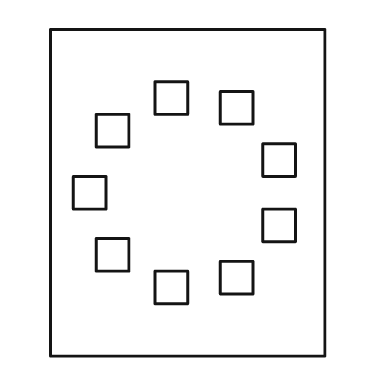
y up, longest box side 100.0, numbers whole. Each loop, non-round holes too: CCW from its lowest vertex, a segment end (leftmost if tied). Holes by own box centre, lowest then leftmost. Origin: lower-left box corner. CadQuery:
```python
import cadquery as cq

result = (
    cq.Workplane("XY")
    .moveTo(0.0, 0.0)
    .lineTo(84.0, 0.0)
    .lineTo(84.0, 100.0)
    .lineTo(0.0, 100.0)
    .close()
    .moveTo(32.0, 16.0)
    .lineTo(42.0, 16.0)
    .lineTo(42.0, 26.0)
    .lineTo(32.0, 26.0)
    .close()
    .moveTo(52.0, 19.0)
    .lineTo(62.0, 19.0)
    .lineTo(62.0, 29.0)
    .lineTo(52.0, 29.0)
    .close()
    .moveTo(14.0, 26.0)
    .lineTo(24.0, 26.0)
    .lineTo(24.0, 36.0)
    .lineTo(14.0, 36.0)
    .close()
    .moveTo(65.0, 35.0)
    .lineTo(75.0, 35.0)
    .lineTo(75.0, 45.0)
    .lineTo(65.0, 45.0)
    .close()
    .moveTo(7.0, 45.0)
    .lineTo(17.0, 45.0)
    .lineTo(17.0, 55.0)
    .lineTo(7.0, 55.0)
    .close()
    .moveTo(65.0, 55.0)
    .lineTo(75.0, 55.0)
    .lineTo(75.0, 65.0)
    .lineTo(65.0, 65.0)
    .close()
    .moveTo(14.0, 64.0)
    .lineTo(24.0, 64.0)
    .lineTo(24.0, 74.0)
    .lineTo(14.0, 74.0)
    .close()
    .moveTo(52.0, 71.0)
    .lineTo(62.0, 71.0)
    .lineTo(62.0, 81.0)
    .lineTo(52.0, 81.0)
    .close()
    .moveTo(32.0, 74.0)
    .lineTo(42.0, 74.0)
    .lineTo(42.0, 84.0)
    .lineTo(32.0, 84.0)
    .close()
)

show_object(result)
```